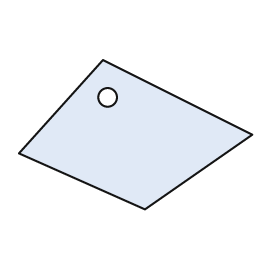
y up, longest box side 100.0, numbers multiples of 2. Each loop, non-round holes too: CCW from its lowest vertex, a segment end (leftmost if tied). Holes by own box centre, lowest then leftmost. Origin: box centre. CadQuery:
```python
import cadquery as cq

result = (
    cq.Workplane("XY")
    .moveTo(4.0, -32.0)
    .lineTo(50.0, 0.0)
    .lineTo(-14.0, 32.0)
    .lineTo(-50.0, -8.0)
    .close()
    .moveTo(-12.0, 16.0)
    .circle(4.0)
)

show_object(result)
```